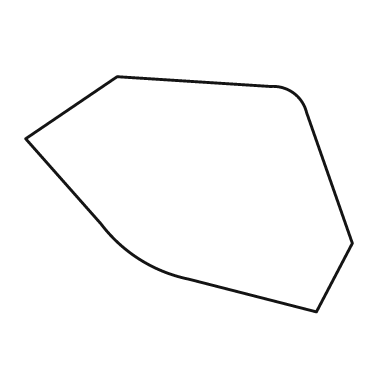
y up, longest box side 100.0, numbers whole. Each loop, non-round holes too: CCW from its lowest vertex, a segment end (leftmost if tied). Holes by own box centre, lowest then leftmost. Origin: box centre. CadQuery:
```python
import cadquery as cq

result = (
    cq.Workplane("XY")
    .moveTo(39.0, -36.0)
    .lineTo(50.0, -15.0)
    .lineTo(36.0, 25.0)
    .threePointArc((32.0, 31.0), (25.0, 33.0))
    .lineTo(-22.0, 36.0)
    .lineTo(-50.0, 17.0)
    .lineTo(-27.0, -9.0)
    .threePointArc((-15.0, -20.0), (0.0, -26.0))
    .close()
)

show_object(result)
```